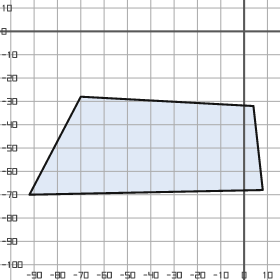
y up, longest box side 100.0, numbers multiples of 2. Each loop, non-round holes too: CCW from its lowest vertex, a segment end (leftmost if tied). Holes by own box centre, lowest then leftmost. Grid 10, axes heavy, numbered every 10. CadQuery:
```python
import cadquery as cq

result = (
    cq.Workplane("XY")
    .moveTo(-92.0, -70.0)
    .lineTo(8.0, -68.0)
    .lineTo(4.0, -32.0)
    .lineTo(-70.0, -28.0)
    .close()
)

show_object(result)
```